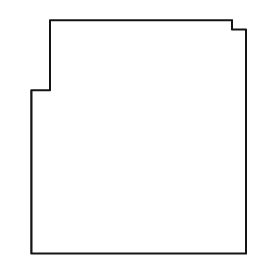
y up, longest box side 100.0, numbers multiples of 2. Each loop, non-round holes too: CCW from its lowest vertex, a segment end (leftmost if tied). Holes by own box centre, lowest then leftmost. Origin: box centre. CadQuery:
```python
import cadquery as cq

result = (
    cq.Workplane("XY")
    .moveTo(-46.0, -50.0)
    .lineTo(46.0, -50.0)
    .lineTo(46.0, 46.0)
    .lineTo(40.0, 46.0)
    .lineTo(40.0, 50.0)
    .lineTo(-38.0, 50.0)
    .lineTo(-38.0, 20.0)
    .lineTo(-46.0, 20.0)
    .close()
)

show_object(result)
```